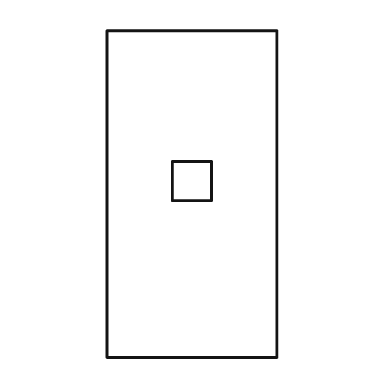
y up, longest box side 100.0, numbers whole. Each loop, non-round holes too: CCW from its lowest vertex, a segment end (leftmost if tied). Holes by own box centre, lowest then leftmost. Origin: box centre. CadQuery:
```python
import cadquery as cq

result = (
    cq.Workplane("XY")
    .moveTo(-26.0, -50.0)
    .lineTo(26.0, -50.0)
    .lineTo(26.0, 50.0)
    .lineTo(-26.0, 50.0)
    .close()
    .moveTo(-6.0, -2.0)
    .lineTo(6.0, -2.0)
    .lineTo(6.0, 10.0)
    .lineTo(-6.0, 10.0)
    .close()
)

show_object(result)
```